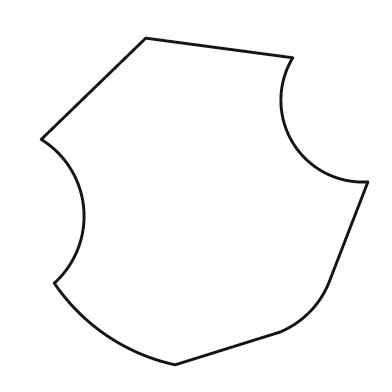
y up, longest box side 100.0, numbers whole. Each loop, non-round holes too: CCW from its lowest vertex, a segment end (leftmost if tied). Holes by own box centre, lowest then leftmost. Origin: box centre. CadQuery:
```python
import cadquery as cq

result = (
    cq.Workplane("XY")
    .moveTo(-9.0, -50.0)
    .lineTo(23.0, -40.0)
    .threePointArc((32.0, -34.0), (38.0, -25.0))
    .lineTo(50.0, 6.0)
    .threePointArc((27.0, 18.0), (27.0, 44.0))
    .lineTo(-18.0, 50.0)
    .lineTo(-50.0, 19.0)
    .threePointArc((-37.0, -2.0), (-46.0, -25.0))
    .threePointArc((-30.0, -41.0), (-9.0, -50.0))
    .close()
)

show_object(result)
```